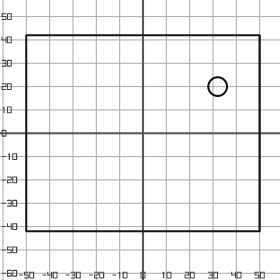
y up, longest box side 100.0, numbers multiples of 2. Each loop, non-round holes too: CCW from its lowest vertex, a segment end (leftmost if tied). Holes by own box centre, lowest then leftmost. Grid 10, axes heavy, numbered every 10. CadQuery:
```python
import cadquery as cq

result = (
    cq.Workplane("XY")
    .moveTo(-50.0, -42.0)
    .lineTo(50.0, -42.0)
    .lineTo(50.0, 42.0)
    .lineTo(-50.0, 42.0)
    .close()
    .moveTo(32.0, 20.0)
    .circle(4.0)
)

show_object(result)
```